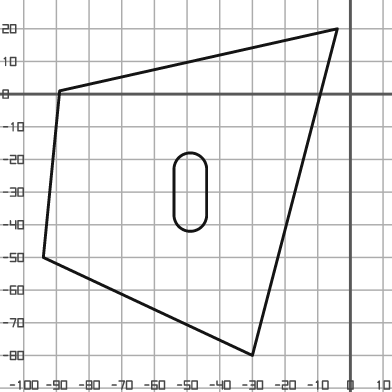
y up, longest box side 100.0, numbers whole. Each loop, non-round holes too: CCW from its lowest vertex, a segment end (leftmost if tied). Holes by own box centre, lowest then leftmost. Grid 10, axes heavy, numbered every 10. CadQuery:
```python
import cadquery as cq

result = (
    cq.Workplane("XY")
    .moveTo(-30.0, -80.0)
    .lineTo(-4.0, 20.0)
    .lineTo(-89.0, 1.0)
    .lineTo(-94.0, -50.0)
    .close()
    .moveTo(-54.0, -37.0)
    .threePointArc((-49.0, -42.0), (-44.0, -37.0))
    .lineTo(-44.0, -23.0)
    .threePointArc((-49.0, -18.0), (-54.0, -23.0))
    .close()
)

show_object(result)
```